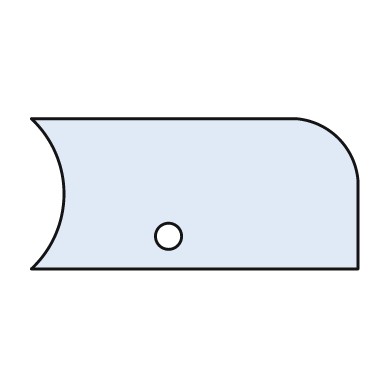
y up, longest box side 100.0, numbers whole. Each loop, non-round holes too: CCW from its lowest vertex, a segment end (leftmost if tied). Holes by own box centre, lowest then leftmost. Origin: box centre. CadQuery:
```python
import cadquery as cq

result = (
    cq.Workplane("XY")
    .moveTo(-50.0, -23.0)
    .lineTo(50.0, -23.0)
    .lineTo(50.0, 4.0)
    .threePointArc((44.0, 17.0), (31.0, 23.0))
    .lineTo(-50.0, 23.0)
    .threePointArc((-40.0, 0.0), (-50.0, -23.0))
    .close()
    .moveTo(-8.0, -13.0)
    .circle(4.0)
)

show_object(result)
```